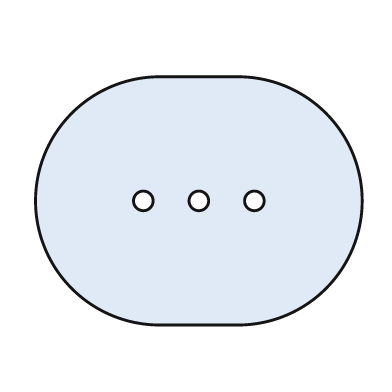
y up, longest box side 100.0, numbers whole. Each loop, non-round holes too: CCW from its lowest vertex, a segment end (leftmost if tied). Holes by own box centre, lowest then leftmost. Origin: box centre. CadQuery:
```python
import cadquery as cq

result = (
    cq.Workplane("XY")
    .moveTo(-12.0, -38.0)
    .lineTo(12.0, -38.0)
    .threePointArc((50.0, 0.0), (12.0, 38.0))
    .lineTo(-12.0, 38.0)
    .threePointArc((-50.0, 0.0), (-12.0, -38.0))
    .close()
    .moveTo(-17.0, 0.0)
    .circle(3.0)
    .moveTo(0.0, 0.0)
    .circle(3.0)
    .moveTo(17.0, 0.0)
    .circle(3.0)
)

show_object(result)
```